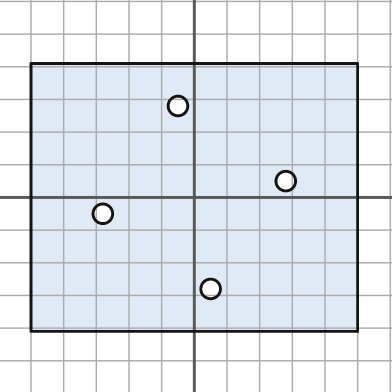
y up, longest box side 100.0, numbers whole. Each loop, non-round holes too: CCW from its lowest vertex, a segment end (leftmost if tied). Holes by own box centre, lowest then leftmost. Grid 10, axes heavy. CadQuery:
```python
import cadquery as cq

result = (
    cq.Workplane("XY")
    .moveTo(-50.0, -41.0)
    .lineTo(50.0, -41.0)
    .lineTo(50.0, 41.0)
    .lineTo(-50.0, 41.0)
    .close()
    .moveTo(5.0, -28.0)
    .circle(3.0)
    .moveTo(-28.0, -5.0)
    .circle(3.0)
    .moveTo(28.0, 5.0)
    .circle(3.0)
    .moveTo(-5.0, 28.0)
    .circle(3.0)
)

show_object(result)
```